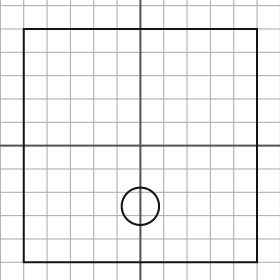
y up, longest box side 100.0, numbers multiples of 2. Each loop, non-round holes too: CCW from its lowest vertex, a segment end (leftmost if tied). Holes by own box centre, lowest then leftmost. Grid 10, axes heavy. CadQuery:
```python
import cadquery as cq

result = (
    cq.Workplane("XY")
    .moveTo(-50.0, -50.0)
    .lineTo(50.0, -50.0)
    .lineTo(50.0, 50.0)
    .lineTo(-50.0, 50.0)
    .close()
    .moveTo(0.0, -26.0)
    .circle(8.0)
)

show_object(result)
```